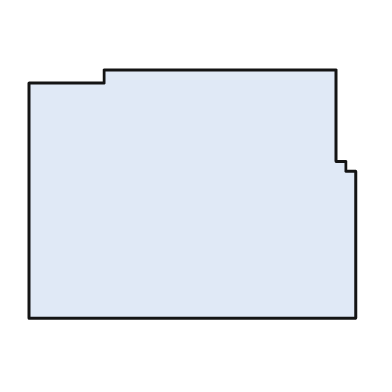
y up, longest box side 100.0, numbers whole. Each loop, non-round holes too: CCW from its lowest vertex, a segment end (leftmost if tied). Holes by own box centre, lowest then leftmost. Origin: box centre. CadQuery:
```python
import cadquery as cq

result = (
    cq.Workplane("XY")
    .moveTo(-50.0, -38.0)
    .lineTo(50.0, -38.0)
    .lineTo(50.0, 7.0)
    .lineTo(47.0, 7.0)
    .lineTo(47.0, 10.0)
    .lineTo(44.0, 10.0)
    .lineTo(44.0, 38.0)
    .lineTo(-27.0, 38.0)
    .lineTo(-27.0, 34.0)
    .lineTo(-50.0, 34.0)
    .close()
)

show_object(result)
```